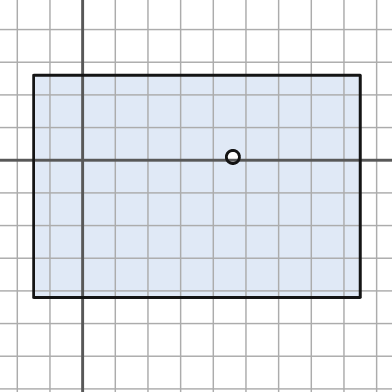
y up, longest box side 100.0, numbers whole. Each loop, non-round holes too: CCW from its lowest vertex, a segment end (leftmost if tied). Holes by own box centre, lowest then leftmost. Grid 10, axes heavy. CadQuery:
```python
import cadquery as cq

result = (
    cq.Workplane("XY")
    .moveTo(-15.0, -42.0)
    .lineTo(85.0, -42.0)
    .lineTo(85.0, 26.0)
    .lineTo(-15.0, 26.0)
    .close()
    .moveTo(46.0, 1.0)
    .circle(2.0)
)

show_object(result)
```